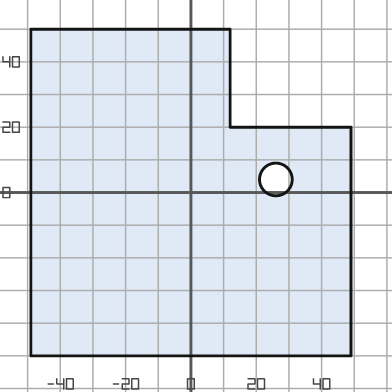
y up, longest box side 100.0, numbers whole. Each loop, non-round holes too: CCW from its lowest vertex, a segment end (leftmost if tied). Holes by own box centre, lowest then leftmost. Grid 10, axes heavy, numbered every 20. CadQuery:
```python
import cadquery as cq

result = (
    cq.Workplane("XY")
    .moveTo(-49.0, -50.0)
    .lineTo(49.0, -50.0)
    .lineTo(49.0, 20.0)
    .lineTo(12.0, 20.0)
    .lineTo(12.0, 50.0)
    .lineTo(-49.0, 50.0)
    .close()
    .moveTo(26.0, 4.0)
    .circle(5.0)
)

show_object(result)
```